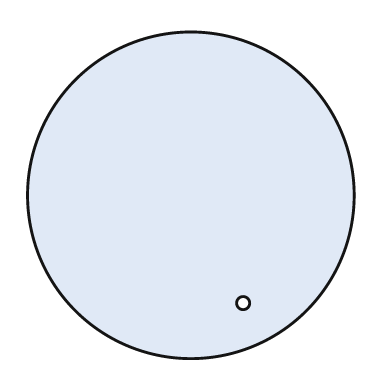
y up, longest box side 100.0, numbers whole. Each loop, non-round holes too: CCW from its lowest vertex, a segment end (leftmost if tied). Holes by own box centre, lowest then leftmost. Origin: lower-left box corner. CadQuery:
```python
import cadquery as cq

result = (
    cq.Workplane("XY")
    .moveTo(50.0, 50.0)
    .circle(50.0)
    .moveTo(66.0, 17.0)
    .circle(2.0)
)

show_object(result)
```